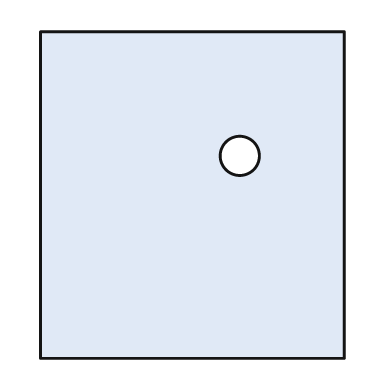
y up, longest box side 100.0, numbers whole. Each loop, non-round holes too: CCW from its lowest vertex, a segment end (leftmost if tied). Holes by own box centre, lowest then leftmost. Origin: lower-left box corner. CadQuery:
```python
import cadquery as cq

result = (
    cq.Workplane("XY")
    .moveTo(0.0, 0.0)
    .lineTo(93.0, 0.0)
    .lineTo(93.0, 100.0)
    .lineTo(0.0, 100.0)
    .close()
    .moveTo(61.0, 62.0)
    .circle(6.0)
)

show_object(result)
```